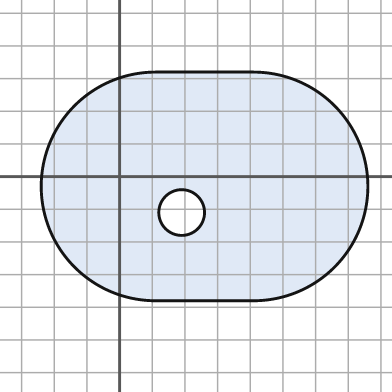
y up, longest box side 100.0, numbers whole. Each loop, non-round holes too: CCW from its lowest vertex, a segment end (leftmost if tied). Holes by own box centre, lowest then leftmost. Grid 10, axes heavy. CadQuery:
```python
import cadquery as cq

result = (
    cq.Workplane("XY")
    .moveTo(11.0, -38.0)
    .lineTo(41.0, -38.0)
    .threePointArc((76.0, -3.0), (41.0, 32.0))
    .lineTo(11.0, 32.0)
    .threePointArc((-24.0, -3.0), (11.0, -38.0))
    .close()
    .moveTo(19.0, -11.0)
    .circle(7.0)
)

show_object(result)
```